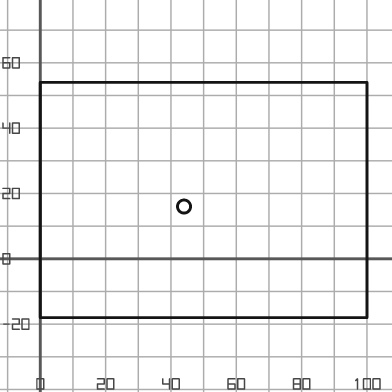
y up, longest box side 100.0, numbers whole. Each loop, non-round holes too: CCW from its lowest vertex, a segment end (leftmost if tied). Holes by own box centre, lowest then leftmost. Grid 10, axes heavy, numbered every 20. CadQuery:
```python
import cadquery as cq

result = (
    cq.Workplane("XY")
    .moveTo(0.0, -18.0)
    .lineTo(100.0, -18.0)
    .lineTo(100.0, 54.0)
    .lineTo(0.0, 54.0)
    .close()
    .moveTo(44.0, 16.0)
    .circle(2.0)
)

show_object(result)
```